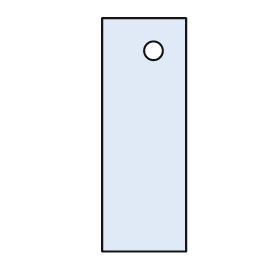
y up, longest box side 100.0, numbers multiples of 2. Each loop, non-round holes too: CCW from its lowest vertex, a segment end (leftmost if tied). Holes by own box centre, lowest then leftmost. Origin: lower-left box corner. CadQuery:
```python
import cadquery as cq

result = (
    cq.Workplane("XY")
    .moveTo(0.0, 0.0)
    .lineTo(36.0, 0.0)
    .lineTo(36.0, 100.0)
    .lineTo(0.0, 100.0)
    .close()
    .moveTo(22.0, 86.0)
    .circle(4.0)
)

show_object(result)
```